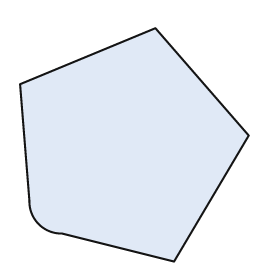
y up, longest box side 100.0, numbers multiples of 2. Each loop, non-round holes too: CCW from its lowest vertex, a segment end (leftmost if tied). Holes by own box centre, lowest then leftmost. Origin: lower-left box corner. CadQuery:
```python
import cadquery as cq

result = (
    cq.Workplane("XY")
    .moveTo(66.0, 0.0)
    .lineTo(98.0, 54.0)
    .lineTo(58.0, 100.0)
    .lineTo(0.0, 76.0)
    .lineTo(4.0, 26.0)
    .threePointArc((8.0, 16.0), (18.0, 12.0))
    .close()
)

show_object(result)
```